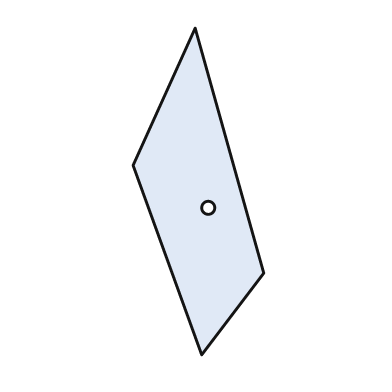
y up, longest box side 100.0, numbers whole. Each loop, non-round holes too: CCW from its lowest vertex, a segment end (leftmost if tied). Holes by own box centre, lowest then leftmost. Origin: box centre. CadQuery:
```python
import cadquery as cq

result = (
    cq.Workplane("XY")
    .moveTo(1.0, -50.0)
    .lineTo(20.0, -25.0)
    .lineTo(-1.0, 50.0)
    .lineTo(-20.0, 8.0)
    .close()
    .moveTo(3.0, -5.0)
    .circle(2.0)
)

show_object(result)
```